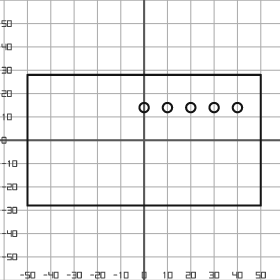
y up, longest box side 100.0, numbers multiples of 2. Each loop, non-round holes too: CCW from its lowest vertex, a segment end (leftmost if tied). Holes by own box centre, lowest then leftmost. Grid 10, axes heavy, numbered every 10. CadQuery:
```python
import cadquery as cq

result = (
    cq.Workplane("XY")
    .moveTo(-50.0, -28.0)
    .lineTo(50.0, -28.0)
    .lineTo(50.0, 28.0)
    .lineTo(-50.0, 28.0)
    .close()
    .moveTo(0.0, 14.0)
    .circle(2.0)
    .moveTo(10.0, 14.0)
    .circle(2.0)
    .moveTo(20.0, 14.0)
    .circle(2.0)
    .moveTo(30.0, 14.0)
    .circle(2.0)
    .moveTo(40.0, 14.0)
    .circle(2.0)
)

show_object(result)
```